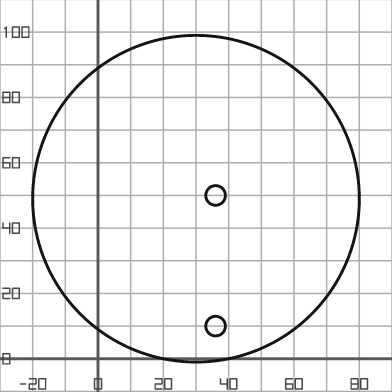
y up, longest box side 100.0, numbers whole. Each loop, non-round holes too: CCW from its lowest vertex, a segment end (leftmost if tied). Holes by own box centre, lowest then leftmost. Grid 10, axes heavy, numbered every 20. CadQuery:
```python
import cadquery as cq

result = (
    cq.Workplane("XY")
    .moveTo(30.0, 49.0)
    .circle(50.0)
    .moveTo(36.0, 10.0)
    .circle(3.0)
    .moveTo(36.0, 50.0)
    .circle(3.0)
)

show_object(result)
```